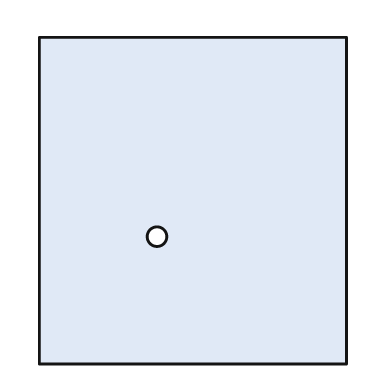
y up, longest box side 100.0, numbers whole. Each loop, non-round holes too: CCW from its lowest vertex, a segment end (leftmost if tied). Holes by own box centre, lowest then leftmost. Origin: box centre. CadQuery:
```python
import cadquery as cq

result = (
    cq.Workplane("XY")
    .moveTo(-47.0, -50.0)
    .lineTo(47.0, -50.0)
    .lineTo(47.0, 50.0)
    .lineTo(-47.0, 50.0)
    .close()
    .moveTo(-11.0, -11.0)
    .circle(3.0)
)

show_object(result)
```